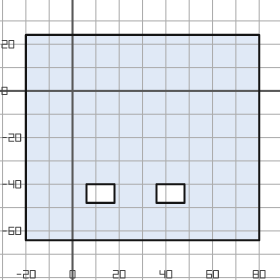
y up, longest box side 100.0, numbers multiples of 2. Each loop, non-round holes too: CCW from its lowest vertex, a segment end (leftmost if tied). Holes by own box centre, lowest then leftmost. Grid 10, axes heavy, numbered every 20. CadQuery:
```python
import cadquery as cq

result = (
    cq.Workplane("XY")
    .moveTo(-20.0, -64.0)
    .lineTo(80.0, -64.0)
    .lineTo(80.0, 24.0)
    .lineTo(-20.0, 24.0)
    .close()
    .moveTo(6.0, -48.0)
    .lineTo(18.0, -48.0)
    .lineTo(18.0, -40.0)
    .lineTo(6.0, -40.0)
    .close()
    .moveTo(36.0, -48.0)
    .lineTo(48.0, -48.0)
    .lineTo(48.0, -40.0)
    .lineTo(36.0, -40.0)
    .close()
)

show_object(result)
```